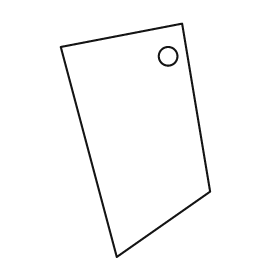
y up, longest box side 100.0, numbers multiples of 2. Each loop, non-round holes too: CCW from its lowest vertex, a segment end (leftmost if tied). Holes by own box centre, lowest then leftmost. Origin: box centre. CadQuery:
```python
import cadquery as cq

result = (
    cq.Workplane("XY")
    .moveTo(-8.0, -50.0)
    .lineTo(32.0, -22.0)
    .lineTo(20.0, 50.0)
    .lineTo(-32.0, 40.0)
    .close()
    .moveTo(14.0, 36.0)
    .circle(4.0)
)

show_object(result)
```